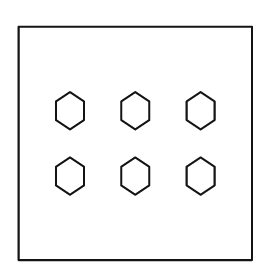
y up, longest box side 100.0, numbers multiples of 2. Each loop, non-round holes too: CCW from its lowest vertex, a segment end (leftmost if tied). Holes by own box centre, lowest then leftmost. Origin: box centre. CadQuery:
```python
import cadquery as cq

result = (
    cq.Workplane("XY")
    .moveTo(-50.0, -50.0)
    .lineTo(50.0, -50.0)
    .lineTo(50.0, 50.0)
    .lineTo(-50.0, 50.0)
    .close()
    .moveTo(-28.0, -22.0)
    .lineTo(-22.0, -18.0)
    .lineTo(-22.0, -10.0)
    .lineTo(-28.0, -6.0)
    .lineTo(-34.0, -10.0)
    .lineTo(-34.0, -18.0)
    .close()
    .moveTo(0.0, -22.0)
    .lineTo(6.0, -18.0)
    .lineTo(6.0, -10.0)
    .lineTo(0.0, -6.0)
    .lineTo(-6.0, -10.0)
    .lineTo(-6.0, -18.0)
    .close()
    .moveTo(28.0, -22.0)
    .lineTo(34.0, -18.0)
    .lineTo(34.0, -10.0)
    .lineTo(28.0, -6.0)
    .lineTo(22.0, -10.0)
    .lineTo(22.0, -18.0)
    .close()
    .moveTo(-28.0, 6.0)
    .lineTo(-22.0, 10.0)
    .lineTo(-22.0, 18.0)
    .lineTo(-28.0, 22.0)
    .lineTo(-34.0, 18.0)
    .lineTo(-34.0, 10.0)
    .close()
    .moveTo(0.0, 6.0)
    .lineTo(6.0, 10.0)
    .lineTo(6.0, 18.0)
    .lineTo(0.0, 22.0)
    .lineTo(-6.0, 18.0)
    .lineTo(-6.0, 10.0)
    .close()
    .moveTo(28.0, 6.0)
    .lineTo(34.0, 10.0)
    .lineTo(34.0, 18.0)
    .lineTo(28.0, 22.0)
    .lineTo(22.0, 18.0)
    .lineTo(22.0, 10.0)
    .close()
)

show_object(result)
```